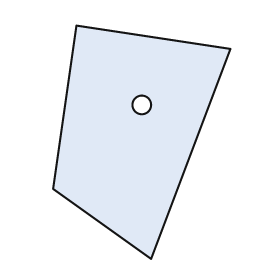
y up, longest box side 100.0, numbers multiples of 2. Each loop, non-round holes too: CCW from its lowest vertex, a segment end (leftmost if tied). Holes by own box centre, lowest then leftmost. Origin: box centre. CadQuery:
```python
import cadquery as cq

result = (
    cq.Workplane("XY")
    .moveTo(4.0, -50.0)
    .lineTo(38.0, 40.0)
    .lineTo(-28.0, 50.0)
    .lineTo(-38.0, -20.0)
    .close()
    .moveTo(0.0, 16.0)
    .circle(4.0)
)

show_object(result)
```